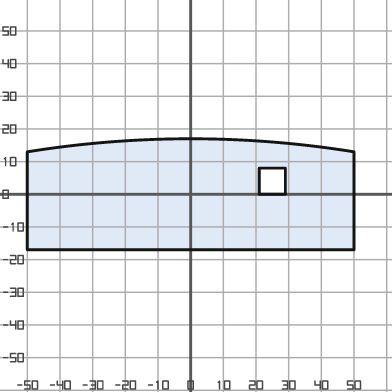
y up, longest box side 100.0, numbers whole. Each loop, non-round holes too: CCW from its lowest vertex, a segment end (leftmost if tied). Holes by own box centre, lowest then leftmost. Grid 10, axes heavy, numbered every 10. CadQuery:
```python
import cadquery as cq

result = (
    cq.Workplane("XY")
    .moveTo(-50.0, -17.0)
    .lineTo(50.0, -17.0)
    .lineTo(50.0, 13.0)
    .threePointArc((0.0, 17.0), (-50.0, 13.0))
    .close()
    .moveTo(21.0, 0.0)
    .lineTo(29.0, 0.0)
    .lineTo(29.0, 8.0)
    .lineTo(21.0, 8.0)
    .close()
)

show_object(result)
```